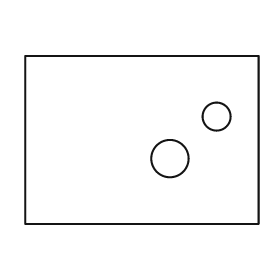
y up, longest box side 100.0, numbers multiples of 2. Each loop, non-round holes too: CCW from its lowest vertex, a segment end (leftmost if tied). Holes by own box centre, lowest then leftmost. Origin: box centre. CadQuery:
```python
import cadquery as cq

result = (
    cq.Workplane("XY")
    .moveTo(-50.0, -36.0)
    .lineTo(50.0, -36.0)
    .lineTo(50.0, 36.0)
    .lineTo(-50.0, 36.0)
    .close()
    .moveTo(12.0, -8.0)
    .circle(8.0)
    .moveTo(32.0, 10.0)
    .circle(6.0)
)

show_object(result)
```